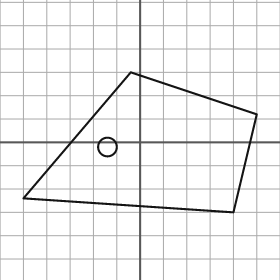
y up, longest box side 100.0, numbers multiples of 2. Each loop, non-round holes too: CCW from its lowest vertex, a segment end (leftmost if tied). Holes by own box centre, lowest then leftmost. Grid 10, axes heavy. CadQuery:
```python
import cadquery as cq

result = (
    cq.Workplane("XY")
    .moveTo(40.0, -30.0)
    .lineTo(50.0, 12.0)
    .lineTo(-4.0, 30.0)
    .lineTo(-50.0, -24.0)
    .close()
    .moveTo(-14.0, -2.0)
    .circle(4.0)
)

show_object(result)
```